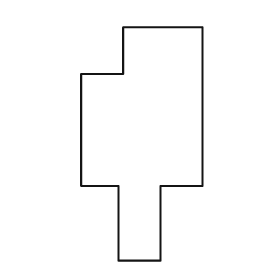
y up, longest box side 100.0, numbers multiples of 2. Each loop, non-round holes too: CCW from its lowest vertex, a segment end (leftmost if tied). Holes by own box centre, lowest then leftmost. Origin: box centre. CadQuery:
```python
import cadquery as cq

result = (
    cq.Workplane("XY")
    .moveTo(-10.0, -50.0)
    .lineTo(8.0, -50.0)
    .lineTo(8.0, -18.0)
    .lineTo(26.0, -18.0)
    .lineTo(26.0, 50.0)
    .lineTo(-8.0, 50.0)
    .lineTo(-8.0, 30.0)
    .lineTo(-26.0, 30.0)
    .lineTo(-26.0, -18.0)
    .lineTo(-10.0, -18.0)
    .close()
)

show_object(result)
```